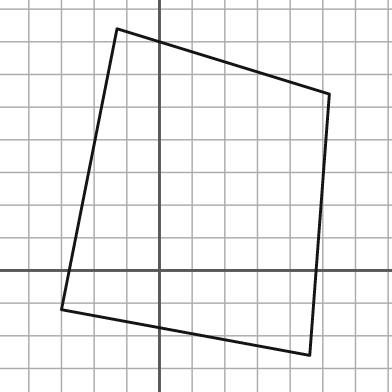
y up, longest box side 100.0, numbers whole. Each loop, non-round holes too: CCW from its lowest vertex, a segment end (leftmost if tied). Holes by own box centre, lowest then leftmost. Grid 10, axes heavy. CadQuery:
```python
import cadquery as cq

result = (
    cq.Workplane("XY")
    .moveTo(46.0, -26.0)
    .lineTo(52.0, 54.0)
    .lineTo(-13.0, 74.0)
    .lineTo(-30.0, -12.0)
    .close()
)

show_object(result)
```